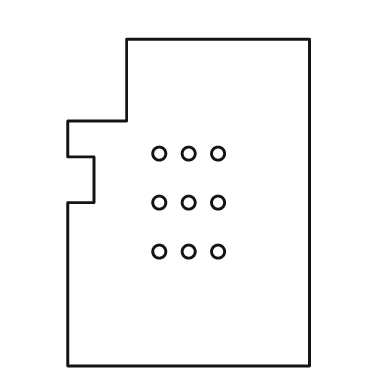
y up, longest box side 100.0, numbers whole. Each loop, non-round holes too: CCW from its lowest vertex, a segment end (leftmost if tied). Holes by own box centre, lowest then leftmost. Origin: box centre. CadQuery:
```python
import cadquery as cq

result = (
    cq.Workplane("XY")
    .moveTo(-37.0, -50.0)
    .lineTo(37.0, -50.0)
    .lineTo(37.0, 50.0)
    .lineTo(-19.0, 50.0)
    .lineTo(-19.0, 25.0)
    .lineTo(-37.0, 25.0)
    .lineTo(-37.0, 14.0)
    .lineTo(-29.0, 14.0)
    .lineTo(-29.0, 0.0)
    .lineTo(-37.0, 0.0)
    .close()
    .moveTo(-9.0, -15.0)
    .circle(2.0)
    .moveTo(0.0, -15.0)
    .circle(2.0)
    .moveTo(9.0, -15.0)
    .circle(2.0)
    .moveTo(-9.0, 0.0)
    .circle(2.0)
    .moveTo(0.0, 0.0)
    .circle(2.0)
    .moveTo(9.0, 0.0)
    .circle(2.0)
    .moveTo(-9.0, 15.0)
    .circle(2.0)
    .moveTo(0.0, 15.0)
    .circle(2.0)
    .moveTo(9.0, 15.0)
    .circle(2.0)
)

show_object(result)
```